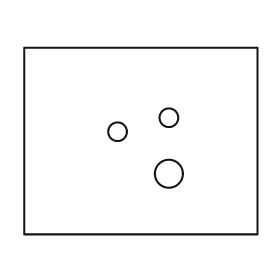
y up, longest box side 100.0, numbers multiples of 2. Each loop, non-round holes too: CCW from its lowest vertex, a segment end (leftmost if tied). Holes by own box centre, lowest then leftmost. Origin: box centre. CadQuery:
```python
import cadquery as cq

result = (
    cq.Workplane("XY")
    .moveTo(-50.0, -40.0)
    .lineTo(50.0, -40.0)
    .lineTo(50.0, 40.0)
    .lineTo(-50.0, 40.0)
    .close()
    .moveTo(12.0, -14.0)
    .circle(6.0)
    .moveTo(-10.0, 4.0)
    .circle(4.0)
    .moveTo(12.0, 10.0)
    .circle(4.0)
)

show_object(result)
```